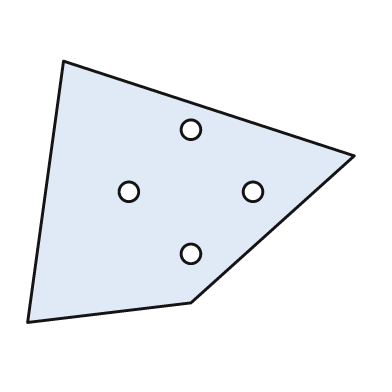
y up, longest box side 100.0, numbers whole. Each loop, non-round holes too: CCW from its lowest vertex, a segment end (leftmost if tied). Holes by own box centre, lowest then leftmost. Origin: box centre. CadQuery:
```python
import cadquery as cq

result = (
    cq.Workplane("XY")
    .moveTo(-50.0, -40.0)
    .lineTo(0.0, -34.0)
    .lineTo(50.0, 11.0)
    .lineTo(-39.0, 40.0)
    .close()
    .moveTo(0.0, -19.0)
    .circle(3.0)
    .moveTo(-19.0, 0.0)
    .circle(3.0)
    .moveTo(19.0, 0.0)
    .circle(3.0)
    .moveTo(0.0, 19.0)
    .circle(3.0)
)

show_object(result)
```